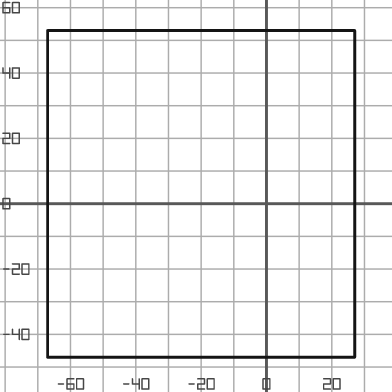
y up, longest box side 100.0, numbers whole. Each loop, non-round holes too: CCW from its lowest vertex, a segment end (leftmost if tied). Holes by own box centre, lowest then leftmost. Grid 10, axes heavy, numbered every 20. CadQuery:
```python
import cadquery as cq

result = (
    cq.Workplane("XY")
    .moveTo(-67.0, -47.0)
    .lineTo(27.0, -47.0)
    .lineTo(27.0, 53.0)
    .lineTo(-67.0, 53.0)
    .close()
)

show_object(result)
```